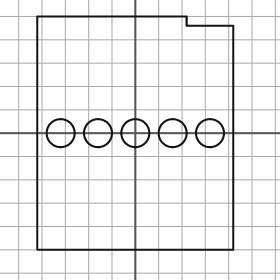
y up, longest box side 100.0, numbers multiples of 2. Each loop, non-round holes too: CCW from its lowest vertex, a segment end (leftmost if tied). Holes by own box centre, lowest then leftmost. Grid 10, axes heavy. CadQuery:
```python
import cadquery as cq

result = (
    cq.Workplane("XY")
    .moveTo(-42.0, -50.0)
    .lineTo(42.0, -50.0)
    .lineTo(42.0, 46.0)
    .lineTo(22.0, 46.0)
    .lineTo(22.0, 50.0)
    .lineTo(-42.0, 50.0)
    .close()
    .moveTo(-32.0, 0.0)
    .circle(6.0)
    .moveTo(-16.0, 0.0)
    .circle(6.0)
    .moveTo(0.0, 0.0)
    .circle(6.0)
    .moveTo(16.0, 0.0)
    .circle(6.0)
    .moveTo(32.0, 0.0)
    .circle(6.0)
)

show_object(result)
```